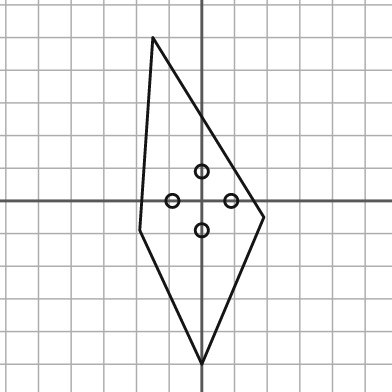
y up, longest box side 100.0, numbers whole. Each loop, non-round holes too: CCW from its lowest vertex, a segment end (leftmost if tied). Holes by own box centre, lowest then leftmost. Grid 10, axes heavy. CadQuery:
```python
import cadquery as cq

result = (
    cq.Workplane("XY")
    .moveTo(0.0, -50.0)
    .lineTo(19.0, -5.0)
    .lineTo(-15.0, 50.0)
    .lineTo(-19.0, -9.0)
    .close()
    .moveTo(0.0, -9.0)
    .circle(2.0)
    .moveTo(-9.0, 0.0)
    .circle(2.0)
    .moveTo(9.0, 0.0)
    .circle(2.0)
    .moveTo(0.0, 9.0)
    .circle(2.0)
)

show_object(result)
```